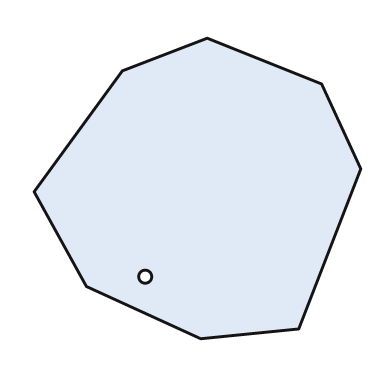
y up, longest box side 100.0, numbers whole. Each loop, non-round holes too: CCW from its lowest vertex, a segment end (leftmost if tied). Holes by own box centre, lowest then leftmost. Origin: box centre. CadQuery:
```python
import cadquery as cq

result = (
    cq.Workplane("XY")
    .moveTo(1.0, -46.0)
    .lineTo(31.0, -43.0)
    .lineTo(50.0, 6.0)
    .lineTo(38.0, 32.0)
    .lineTo(3.0, 46.0)
    .lineTo(-23.0, 36.0)
    .lineTo(-50.0, -1.0)
    .lineTo(-34.0, -30.0)
    .close()
    .moveTo(-16.0, -27.0)
    .circle(2.0)
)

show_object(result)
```